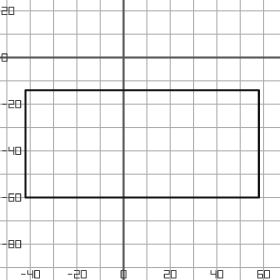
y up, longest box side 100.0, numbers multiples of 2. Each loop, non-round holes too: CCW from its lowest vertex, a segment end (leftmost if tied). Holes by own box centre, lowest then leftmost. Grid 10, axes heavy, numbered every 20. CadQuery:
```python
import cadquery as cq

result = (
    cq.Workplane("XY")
    .moveTo(-42.0, -60.0)
    .lineTo(58.0, -60.0)
    .lineTo(58.0, -14.0)
    .lineTo(-42.0, -14.0)
    .close()
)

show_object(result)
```